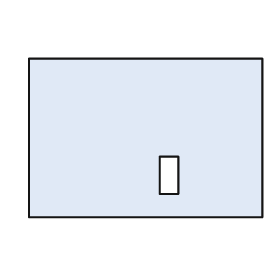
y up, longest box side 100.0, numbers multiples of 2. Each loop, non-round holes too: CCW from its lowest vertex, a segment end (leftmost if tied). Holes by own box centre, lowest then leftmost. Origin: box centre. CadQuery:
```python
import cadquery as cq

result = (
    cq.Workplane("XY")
    .moveTo(-50.0, -34.0)
    .lineTo(50.0, -34.0)
    .lineTo(50.0, 34.0)
    .lineTo(-50.0, 34.0)
    .close()
    .moveTo(6.0, -24.0)
    .lineTo(14.0, -24.0)
    .lineTo(14.0, -8.0)
    .lineTo(6.0, -8.0)
    .close()
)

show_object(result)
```